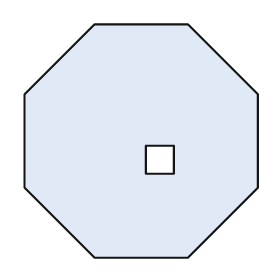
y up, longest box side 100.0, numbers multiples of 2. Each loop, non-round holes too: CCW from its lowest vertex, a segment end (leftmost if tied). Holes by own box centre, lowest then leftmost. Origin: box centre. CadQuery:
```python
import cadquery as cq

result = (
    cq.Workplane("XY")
    .moveTo(-20.0, -50.0)
    .lineTo(20.0, -50.0)
    .lineTo(50.0, -20.0)
    .lineTo(50.0, 20.0)
    .lineTo(20.0, 50.0)
    .lineTo(-20.0, 50.0)
    .lineTo(-50.0, 20.0)
    .lineTo(-50.0, -20.0)
    .close()
    .moveTo(2.0, -14.0)
    .lineTo(14.0, -14.0)
    .lineTo(14.0, -2.0)
    .lineTo(2.0, -2.0)
    .close()
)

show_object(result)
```